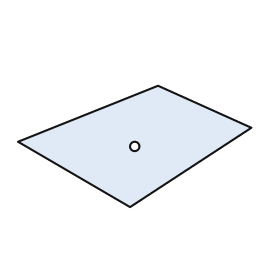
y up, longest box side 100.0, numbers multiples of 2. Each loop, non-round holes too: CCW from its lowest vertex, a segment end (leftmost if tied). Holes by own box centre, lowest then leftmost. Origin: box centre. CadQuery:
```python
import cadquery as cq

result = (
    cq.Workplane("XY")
    .moveTo(-2.0, -26.0)
    .lineTo(50.0, 8.0)
    .lineTo(10.0, 26.0)
    .lineTo(-50.0, 2.0)
    .close()
    .moveTo(0.0, 0.0)
    .circle(2.0)
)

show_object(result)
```